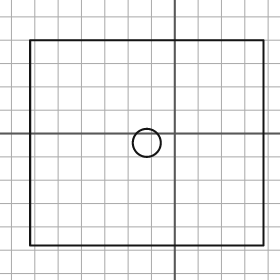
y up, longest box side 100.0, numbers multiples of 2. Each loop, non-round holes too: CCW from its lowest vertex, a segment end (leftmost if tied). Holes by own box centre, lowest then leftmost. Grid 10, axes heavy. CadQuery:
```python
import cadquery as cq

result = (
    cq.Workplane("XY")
    .moveTo(-62.0, -48.0)
    .lineTo(38.0, -48.0)
    .lineTo(38.0, 40.0)
    .lineTo(-62.0, 40.0)
    .close()
    .moveTo(-12.0, -4.0)
    .circle(6.0)
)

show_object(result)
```